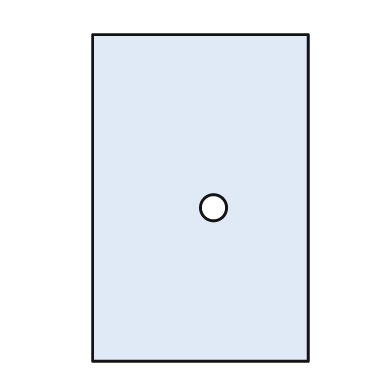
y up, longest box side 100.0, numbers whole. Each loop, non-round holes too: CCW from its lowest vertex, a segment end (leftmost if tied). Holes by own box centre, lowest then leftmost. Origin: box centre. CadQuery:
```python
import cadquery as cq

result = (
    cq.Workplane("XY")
    .moveTo(-33.0, -50.0)
    .lineTo(33.0, -50.0)
    .lineTo(33.0, 50.0)
    .lineTo(-33.0, 50.0)
    .close()
    .moveTo(4.0, -3.0)
    .circle(4.0)
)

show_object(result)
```